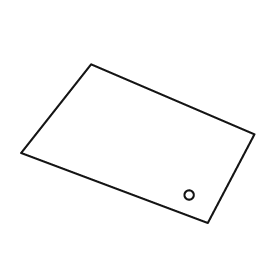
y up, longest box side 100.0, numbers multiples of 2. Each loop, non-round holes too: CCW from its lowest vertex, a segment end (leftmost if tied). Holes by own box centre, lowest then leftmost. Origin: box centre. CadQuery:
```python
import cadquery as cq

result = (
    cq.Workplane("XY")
    .moveTo(30.0, -34.0)
    .lineTo(50.0, 4.0)
    .lineTo(-20.0, 34.0)
    .lineTo(-50.0, -4.0)
    .close()
    .moveTo(22.0, -22.0)
    .circle(2.0)
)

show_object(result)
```